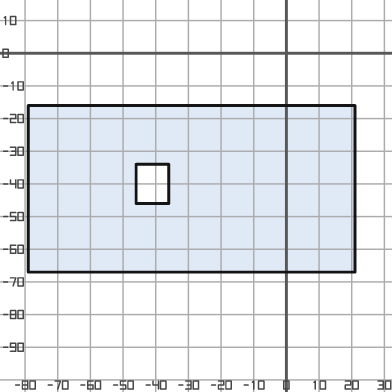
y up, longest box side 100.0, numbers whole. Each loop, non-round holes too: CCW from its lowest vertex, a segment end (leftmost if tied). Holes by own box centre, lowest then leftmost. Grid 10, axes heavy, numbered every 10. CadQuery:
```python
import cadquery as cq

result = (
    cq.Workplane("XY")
    .moveTo(-79.0, -67.0)
    .lineTo(21.0, -67.0)
    .lineTo(21.0, -16.0)
    .lineTo(-79.0, -16.0)
    .close()
    .moveTo(-46.0, -46.0)
    .lineTo(-36.0, -46.0)
    .lineTo(-36.0, -34.0)
    .lineTo(-46.0, -34.0)
    .close()
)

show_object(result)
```